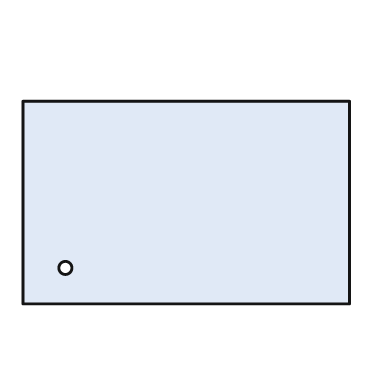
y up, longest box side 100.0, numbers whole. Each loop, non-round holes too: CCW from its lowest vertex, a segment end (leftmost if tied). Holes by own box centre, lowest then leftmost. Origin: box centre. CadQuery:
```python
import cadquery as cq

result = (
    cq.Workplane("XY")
    .moveTo(-50.0, -31.0)
    .lineTo(50.0, -31.0)
    .lineTo(50.0, 31.0)
    .lineTo(-50.0, 31.0)
    .close()
    .moveTo(-37.0, -20.0)
    .circle(2.0)
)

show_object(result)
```